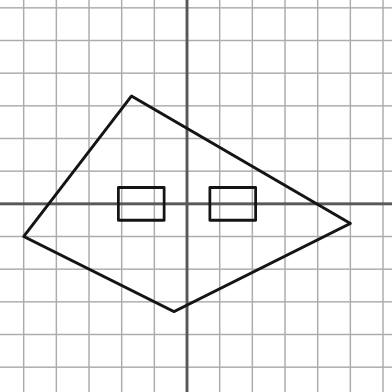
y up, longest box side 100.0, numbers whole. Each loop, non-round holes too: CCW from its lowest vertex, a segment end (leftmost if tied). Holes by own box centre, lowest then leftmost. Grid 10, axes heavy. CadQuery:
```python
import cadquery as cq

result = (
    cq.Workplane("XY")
    .moveTo(-4.0, -33.0)
    .lineTo(50.0, -6.0)
    .lineTo(-17.0, 33.0)
    .lineTo(-50.0, -10.0)
    .close()
    .moveTo(-21.0, -5.0)
    .lineTo(-7.0, -5.0)
    .lineTo(-7.0, 5.0)
    .lineTo(-21.0, 5.0)
    .close()
    .moveTo(7.0, -5.0)
    .lineTo(21.0, -5.0)
    .lineTo(21.0, 5.0)
    .lineTo(7.0, 5.0)
    .close()
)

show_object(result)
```